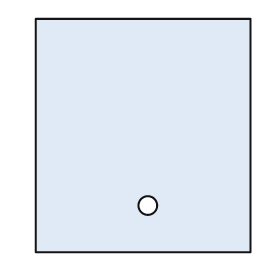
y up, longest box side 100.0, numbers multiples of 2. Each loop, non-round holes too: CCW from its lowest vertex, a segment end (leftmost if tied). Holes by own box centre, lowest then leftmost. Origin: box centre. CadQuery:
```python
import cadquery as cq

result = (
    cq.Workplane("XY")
    .moveTo(-46.0, -50.0)
    .lineTo(46.0, -50.0)
    .lineTo(46.0, 50.0)
    .lineTo(-46.0, 50.0)
    .close()
    .moveTo(2.0, -30.0)
    .circle(4.0)
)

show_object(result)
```